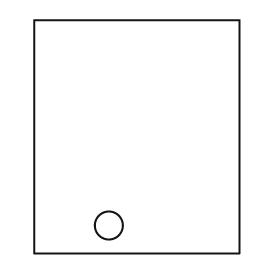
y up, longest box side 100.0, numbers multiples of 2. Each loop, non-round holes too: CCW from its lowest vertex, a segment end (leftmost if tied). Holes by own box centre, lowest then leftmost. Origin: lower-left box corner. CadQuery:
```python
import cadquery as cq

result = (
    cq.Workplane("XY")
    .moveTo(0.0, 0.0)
    .lineTo(88.0, 0.0)
    .lineTo(88.0, 100.0)
    .lineTo(0.0, 100.0)
    .close()
    .moveTo(32.0, 12.0)
    .circle(6.0)
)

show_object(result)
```